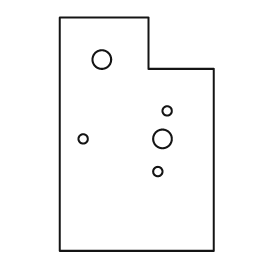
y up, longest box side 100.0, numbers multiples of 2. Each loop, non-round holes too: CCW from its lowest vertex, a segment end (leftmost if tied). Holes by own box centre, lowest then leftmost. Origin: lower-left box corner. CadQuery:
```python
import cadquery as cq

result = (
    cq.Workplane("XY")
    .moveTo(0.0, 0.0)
    .lineTo(66.0, 0.0)
    .lineTo(66.0, 78.0)
    .lineTo(38.0, 78.0)
    .lineTo(38.0, 100.0)
    .lineTo(0.0, 100.0)
    .close()
    .moveTo(42.0, 34.0)
    .circle(2.0)
    .moveTo(10.0, 48.0)
    .circle(2.0)
    .moveTo(44.0, 48.0)
    .circle(4.0)
    .moveTo(46.0, 60.0)
    .circle(2.0)
    .moveTo(18.0, 82.0)
    .circle(4.0)
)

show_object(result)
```